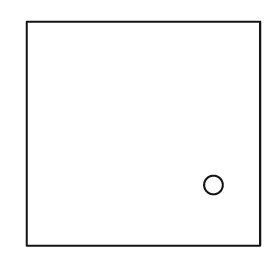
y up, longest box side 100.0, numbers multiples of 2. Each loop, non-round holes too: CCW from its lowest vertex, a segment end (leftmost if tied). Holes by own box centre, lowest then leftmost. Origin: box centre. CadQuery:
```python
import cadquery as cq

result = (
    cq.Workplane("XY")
    .moveTo(-50.0, -48.0)
    .lineTo(50.0, -48.0)
    .lineTo(50.0, 48.0)
    .lineTo(-50.0, 48.0)
    .close()
    .moveTo(30.0, -22.0)
    .circle(4.0)
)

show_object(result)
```